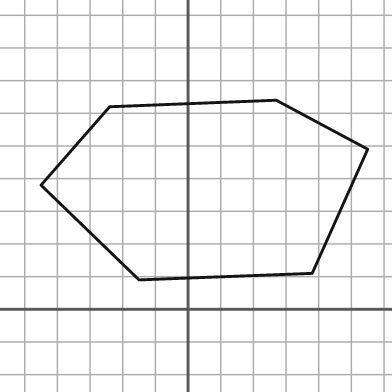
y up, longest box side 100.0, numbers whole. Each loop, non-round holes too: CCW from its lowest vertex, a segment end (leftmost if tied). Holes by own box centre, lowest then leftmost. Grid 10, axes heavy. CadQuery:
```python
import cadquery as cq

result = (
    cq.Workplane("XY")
    .moveTo(-15.0, 9.0)
    .lineTo(38.0, 11.0)
    .lineTo(55.0, 49.0)
    .lineTo(27.0, 64.0)
    .lineTo(-24.0, 62.0)
    .lineTo(-45.0, 38.0)
    .close()
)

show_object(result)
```